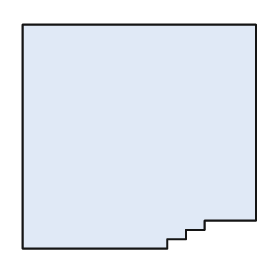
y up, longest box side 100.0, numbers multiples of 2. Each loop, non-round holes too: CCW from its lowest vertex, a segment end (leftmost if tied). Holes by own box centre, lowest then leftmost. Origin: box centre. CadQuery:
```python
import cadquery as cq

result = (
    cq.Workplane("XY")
    .moveTo(-50.0, -48.0)
    .lineTo(12.0, -48.0)
    .lineTo(12.0, -44.0)
    .lineTo(20.0, -44.0)
    .lineTo(20.0, -40.0)
    .lineTo(28.0, -40.0)
    .lineTo(28.0, -36.0)
    .lineTo(50.0, -36.0)
    .lineTo(50.0, 48.0)
    .lineTo(-50.0, 48.0)
    .close()
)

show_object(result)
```